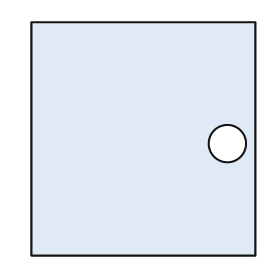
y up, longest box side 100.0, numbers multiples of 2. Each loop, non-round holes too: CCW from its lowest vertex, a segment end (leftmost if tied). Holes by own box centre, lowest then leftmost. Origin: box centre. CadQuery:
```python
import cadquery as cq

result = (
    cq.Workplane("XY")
    .moveTo(-48.0, -50.0)
    .lineTo(48.0, -50.0)
    .lineTo(48.0, 50.0)
    .lineTo(-48.0, 50.0)
    .close()
    .moveTo(36.0, -2.0)
    .circle(8.0)
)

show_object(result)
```